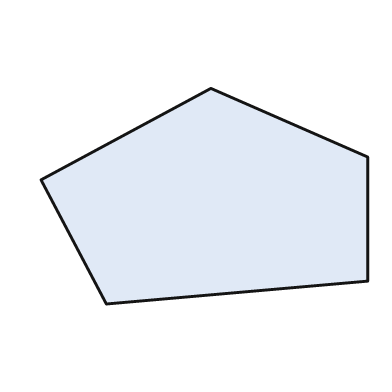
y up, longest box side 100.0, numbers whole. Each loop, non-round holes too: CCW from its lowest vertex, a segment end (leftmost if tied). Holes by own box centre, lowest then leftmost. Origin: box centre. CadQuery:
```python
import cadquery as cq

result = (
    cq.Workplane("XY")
    .moveTo(-30.0, -33.0)
    .lineTo(50.0, -26.0)
    .lineTo(50.0, 12.0)
    .lineTo(2.0, 33.0)
    .lineTo(-50.0, 5.0)
    .close()
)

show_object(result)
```